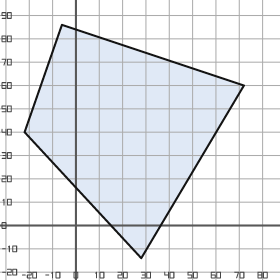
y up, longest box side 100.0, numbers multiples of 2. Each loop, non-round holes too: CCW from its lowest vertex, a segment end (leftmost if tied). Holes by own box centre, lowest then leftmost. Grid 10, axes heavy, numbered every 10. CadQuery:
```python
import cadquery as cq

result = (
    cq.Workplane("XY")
    .moveTo(28.0, -14.0)
    .lineTo(72.0, 60.0)
    .lineTo(-6.0, 86.0)
    .lineTo(-22.0, 40.0)
    .close()
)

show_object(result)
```